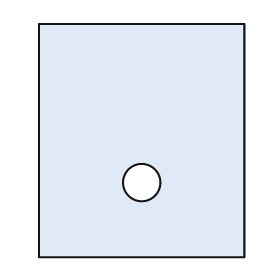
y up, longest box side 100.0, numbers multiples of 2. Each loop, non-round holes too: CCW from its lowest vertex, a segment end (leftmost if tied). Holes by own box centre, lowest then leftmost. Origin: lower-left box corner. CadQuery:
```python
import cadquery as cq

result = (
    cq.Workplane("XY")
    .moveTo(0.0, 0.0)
    .lineTo(88.0, 0.0)
    .lineTo(88.0, 100.0)
    .lineTo(0.0, 100.0)
    .close()
    .moveTo(44.0, 32.0)
    .circle(8.0)
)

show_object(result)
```